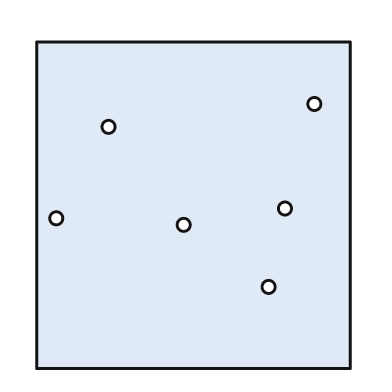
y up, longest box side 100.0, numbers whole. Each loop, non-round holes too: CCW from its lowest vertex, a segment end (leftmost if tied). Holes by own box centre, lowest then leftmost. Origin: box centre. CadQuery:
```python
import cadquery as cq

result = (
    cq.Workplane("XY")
    .moveTo(-48.0, -50.0)
    .lineTo(48.0, -50.0)
    .lineTo(48.0, 50.0)
    .lineTo(-48.0, 50.0)
    .close()
    .moveTo(23.0, -25.0)
    .circle(2.0)
    .moveTo(-3.0, -6.0)
    .circle(2.0)
    .moveTo(-42.0, -4.0)
    .circle(2.0)
    .moveTo(28.0, -1.0)
    .circle(2.0)
    .moveTo(-26.0, 24.0)
    .circle(2.0)
    .moveTo(37.0, 31.0)
    .circle(2.0)
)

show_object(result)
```